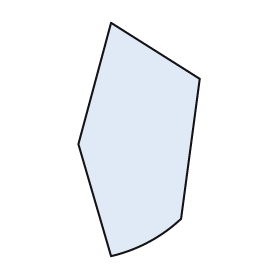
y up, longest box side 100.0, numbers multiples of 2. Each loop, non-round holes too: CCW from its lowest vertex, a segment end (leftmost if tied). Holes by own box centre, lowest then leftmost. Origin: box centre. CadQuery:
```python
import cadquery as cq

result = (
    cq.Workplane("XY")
    .moveTo(-12.0, -50.0)
    .threePointArc((4.0, -44.0), (18.0, -34.0))
    .lineTo(26.0, 26.0)
    .lineTo(-12.0, 50.0)
    .lineTo(-26.0, -2.0)
    .close()
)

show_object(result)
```